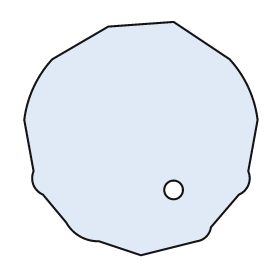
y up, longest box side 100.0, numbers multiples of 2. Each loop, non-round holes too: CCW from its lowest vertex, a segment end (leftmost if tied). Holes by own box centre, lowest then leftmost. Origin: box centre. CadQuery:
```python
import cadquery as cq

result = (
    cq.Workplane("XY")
    .moveTo(0.0, -50.0)
    .lineTo(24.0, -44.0)
    .threePointArc((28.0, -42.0), (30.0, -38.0))
    .lineTo(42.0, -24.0)
    .threePointArc((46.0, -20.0), (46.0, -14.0))
    .lineTo(50.0, 8.0)
    .threePointArc((46.0, 22.0), (38.0, 34.0))
    .lineTo(14.0, 50.0)
    .lineTo(-14.0, 48.0)
    .lineTo(-38.0, 34.0)
    .threePointArc((-46.0, 22.0), (-50.0, 8.0))
    .lineTo(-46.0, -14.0)
    .threePointArc((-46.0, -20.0), (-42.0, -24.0))
    .lineTo(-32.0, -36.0)
    .threePointArc((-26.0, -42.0), (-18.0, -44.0))
    .close()
    .moveTo(14.0, -22.0)
    .circle(4.0)
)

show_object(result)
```